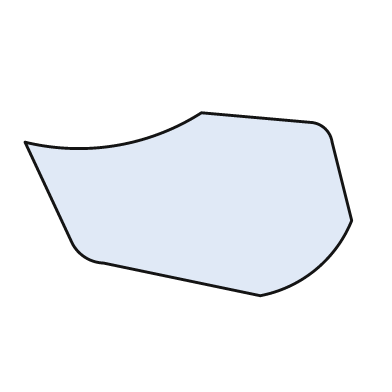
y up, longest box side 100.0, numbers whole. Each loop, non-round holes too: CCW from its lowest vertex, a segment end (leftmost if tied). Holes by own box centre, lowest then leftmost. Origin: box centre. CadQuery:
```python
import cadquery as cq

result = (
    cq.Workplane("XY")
    .moveTo(22.0, -28.0)
    .threePointArc((39.0, -20.0), (50.0, -5.0))
    .lineTo(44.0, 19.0)
    .threePointArc((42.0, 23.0), (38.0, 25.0))
    .lineTo(4.0, 28.0)
    .threePointArc((-22.0, 18.0), (-50.0, 19.0))
    .lineTo(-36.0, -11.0)
    .threePointArc((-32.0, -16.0), (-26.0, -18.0))
    .close()
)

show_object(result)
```